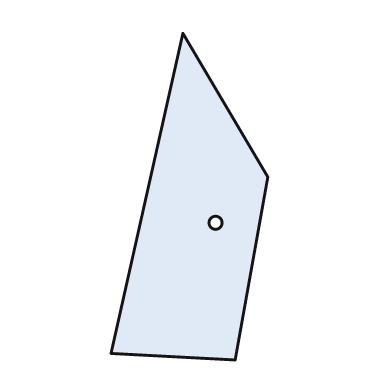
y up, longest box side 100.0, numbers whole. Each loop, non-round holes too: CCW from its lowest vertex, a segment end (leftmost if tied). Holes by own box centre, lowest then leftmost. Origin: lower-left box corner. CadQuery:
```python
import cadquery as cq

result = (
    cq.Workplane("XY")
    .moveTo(38.0, 0.0)
    .lineTo(48.0, 56.0)
    .lineTo(22.0, 100.0)
    .lineTo(0.0, 2.0)
    .close()
    .moveTo(32.0, 42.0)
    .circle(2.0)
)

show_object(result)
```